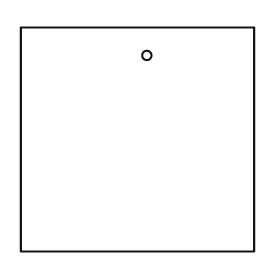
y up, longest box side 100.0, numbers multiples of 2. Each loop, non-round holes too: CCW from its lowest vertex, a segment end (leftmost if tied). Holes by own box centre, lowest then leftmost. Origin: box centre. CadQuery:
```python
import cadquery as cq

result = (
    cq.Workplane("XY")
    .moveTo(-50.0, -48.0)
    .lineTo(50.0, -48.0)
    .lineTo(50.0, 48.0)
    .lineTo(-50.0, 48.0)
    .close()
    .moveTo(4.0, 36.0)
    .circle(2.0)
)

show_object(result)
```